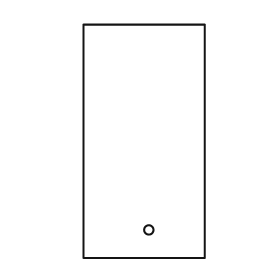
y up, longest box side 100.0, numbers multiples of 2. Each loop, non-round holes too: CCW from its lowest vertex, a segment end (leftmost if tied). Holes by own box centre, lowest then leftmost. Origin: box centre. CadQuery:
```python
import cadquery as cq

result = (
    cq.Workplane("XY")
    .moveTo(-26.0, -50.0)
    .lineTo(26.0, -50.0)
    .lineTo(26.0, 50.0)
    .lineTo(-26.0, 50.0)
    .close()
    .moveTo(2.0, -38.0)
    .circle(2.0)
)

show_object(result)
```